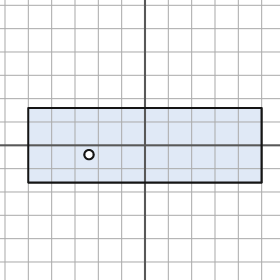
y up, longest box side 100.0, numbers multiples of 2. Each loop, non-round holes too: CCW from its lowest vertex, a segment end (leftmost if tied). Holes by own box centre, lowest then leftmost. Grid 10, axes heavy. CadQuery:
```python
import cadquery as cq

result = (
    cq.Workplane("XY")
    .moveTo(-50.0, -16.0)
    .lineTo(50.0, -16.0)
    .lineTo(50.0, 16.0)
    .lineTo(-50.0, 16.0)
    .close()
    .moveTo(-24.0, -4.0)
    .circle(2.0)
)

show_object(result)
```